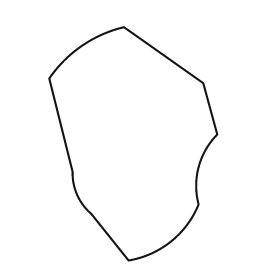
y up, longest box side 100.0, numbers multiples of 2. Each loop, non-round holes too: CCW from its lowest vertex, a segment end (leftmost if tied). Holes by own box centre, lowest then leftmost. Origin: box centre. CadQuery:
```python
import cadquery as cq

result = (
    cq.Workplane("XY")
    .moveTo(-2.0, -50.0)
    .threePointArc((16.0, -42.0), (28.0, -26.0))
    .threePointArc((28.0, -10.0), (36.0, 4.0))
    .lineTo(30.0, 26.0)
    .lineTo(-4.0, 50.0)
    .threePointArc((-22.0, 42.0), (-36.0, 28.0))
    .lineTo(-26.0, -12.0)
    .threePointArc((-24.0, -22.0), (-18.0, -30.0))
    .close()
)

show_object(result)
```